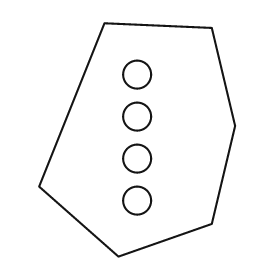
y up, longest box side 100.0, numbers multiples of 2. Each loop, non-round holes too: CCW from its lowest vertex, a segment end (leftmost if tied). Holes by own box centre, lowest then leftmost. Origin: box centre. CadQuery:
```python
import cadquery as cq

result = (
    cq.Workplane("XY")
    .moveTo(-8.0, -50.0)
    .lineTo(32.0, -36.0)
    .lineTo(42.0, 6.0)
    .lineTo(32.0, 48.0)
    .lineTo(-14.0, 50.0)
    .lineTo(-42.0, -20.0)
    .close()
    .moveTo(0.0, -26.0)
    .circle(6.0)
    .moveTo(0.0, -8.0)
    .circle(6.0)
    .moveTo(0.0, 10.0)
    .circle(6.0)
    .moveTo(0.0, 28.0)
    .circle(6.0)
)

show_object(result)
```